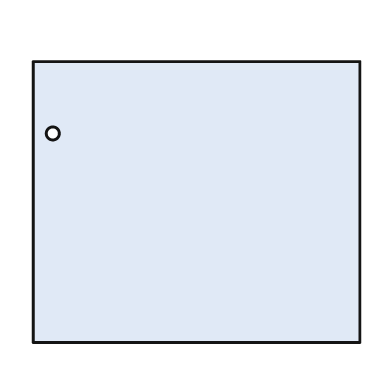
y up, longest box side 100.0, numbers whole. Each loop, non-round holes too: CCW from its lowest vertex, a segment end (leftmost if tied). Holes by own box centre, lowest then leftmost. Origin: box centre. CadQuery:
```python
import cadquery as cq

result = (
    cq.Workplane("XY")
    .moveTo(-50.0, -43.0)
    .lineTo(50.0, -43.0)
    .lineTo(50.0, 43.0)
    .lineTo(-50.0, 43.0)
    .close()
    .moveTo(-44.0, 21.0)
    .circle(2.0)
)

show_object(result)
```